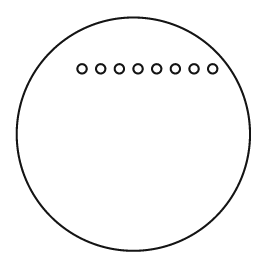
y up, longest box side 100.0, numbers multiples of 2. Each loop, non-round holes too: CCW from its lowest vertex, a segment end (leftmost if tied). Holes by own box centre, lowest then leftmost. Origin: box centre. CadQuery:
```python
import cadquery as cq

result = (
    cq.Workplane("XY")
    .moveTo(0.0, 0.0)
    .circle(50.0)
    .moveTo(-22.0, 28.0)
    .circle(2.0)
    .moveTo(-14.0, 28.0)
    .circle(2.0)
    .moveTo(-6.0, 28.0)
    .circle(2.0)
    .moveTo(2.0, 28.0)
    .circle(2.0)
    .moveTo(10.0, 28.0)
    .circle(2.0)
    .moveTo(18.0, 28.0)
    .circle(2.0)
    .moveTo(26.0, 28.0)
    .circle(2.0)
    .moveTo(34.0, 28.0)
    .circle(2.0)
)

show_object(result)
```